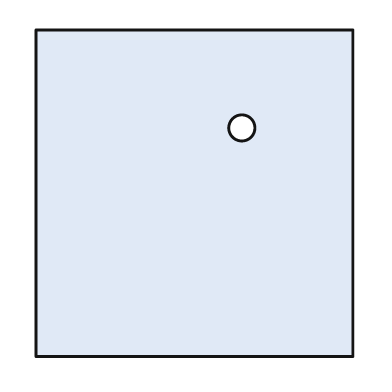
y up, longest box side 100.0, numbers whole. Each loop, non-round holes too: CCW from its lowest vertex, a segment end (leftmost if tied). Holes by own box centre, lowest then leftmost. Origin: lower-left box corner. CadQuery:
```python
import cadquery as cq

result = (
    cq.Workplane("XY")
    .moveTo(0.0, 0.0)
    .lineTo(97.0, 0.0)
    .lineTo(97.0, 100.0)
    .lineTo(0.0, 100.0)
    .close()
    .moveTo(63.0, 70.0)
    .circle(4.0)
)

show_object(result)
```